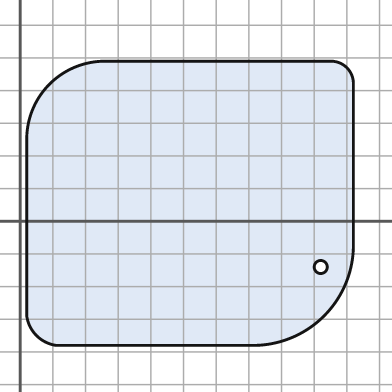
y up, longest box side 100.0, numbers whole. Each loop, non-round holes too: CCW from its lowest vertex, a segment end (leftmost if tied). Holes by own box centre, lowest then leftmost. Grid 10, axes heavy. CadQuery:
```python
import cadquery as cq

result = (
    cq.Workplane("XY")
    .moveTo(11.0, -38.0)
    .lineTo(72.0, -38.0)
    .threePointArc((93.0, -29.0), (102.0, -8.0))
    .lineTo(102.0, 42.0)
    .threePointArc((100.0, 47.0), (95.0, 49.0))
    .lineTo(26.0, 49.0)
    .threePointArc((9.0, 42.0), (2.0, 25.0))
    .lineTo(2.0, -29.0)
    .threePointArc((5.0, -35.0), (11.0, -38.0))
    .close()
    .moveTo(92.0, -14.0)
    .circle(2.0)
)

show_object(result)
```